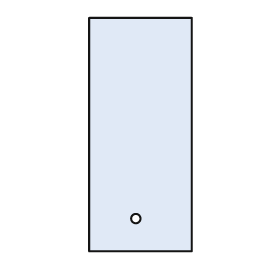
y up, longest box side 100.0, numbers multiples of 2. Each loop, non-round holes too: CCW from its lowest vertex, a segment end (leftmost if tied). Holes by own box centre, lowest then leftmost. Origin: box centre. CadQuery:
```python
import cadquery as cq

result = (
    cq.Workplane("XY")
    .moveTo(-22.0, -50.0)
    .lineTo(22.0, -50.0)
    .lineTo(22.0, 50.0)
    .lineTo(-22.0, 50.0)
    .close()
    .moveTo(-2.0, -36.0)
    .circle(2.0)
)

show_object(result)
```